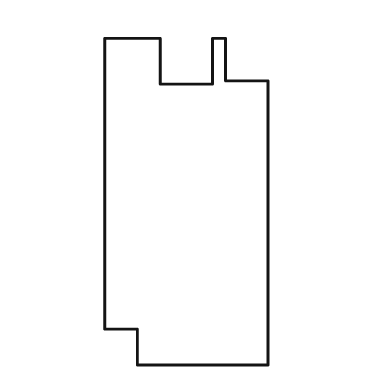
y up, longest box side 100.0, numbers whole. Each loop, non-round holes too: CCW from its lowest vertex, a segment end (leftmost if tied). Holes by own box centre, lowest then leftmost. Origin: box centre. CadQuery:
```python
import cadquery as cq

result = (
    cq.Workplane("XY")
    .moveTo(-15.0, -50.0)
    .lineTo(25.0, -50.0)
    .lineTo(25.0, 37.0)
    .lineTo(12.0, 37.0)
    .lineTo(12.0, 50.0)
    .lineTo(8.0, 50.0)
    .lineTo(8.0, 36.0)
    .lineTo(-8.0, 36.0)
    .lineTo(-8.0, 50.0)
    .lineTo(-25.0, 50.0)
    .lineTo(-25.0, -39.0)
    .lineTo(-15.0, -39.0)
    .close()
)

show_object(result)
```